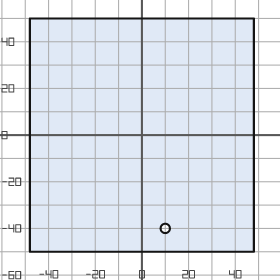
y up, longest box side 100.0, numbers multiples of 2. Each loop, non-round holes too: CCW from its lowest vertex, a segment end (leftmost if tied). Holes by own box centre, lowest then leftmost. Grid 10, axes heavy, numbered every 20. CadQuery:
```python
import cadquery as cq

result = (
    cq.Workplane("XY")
    .moveTo(-48.0, -50.0)
    .lineTo(48.0, -50.0)
    .lineTo(48.0, 50.0)
    .lineTo(-48.0, 50.0)
    .close()
    .moveTo(10.0, -40.0)
    .circle(2.0)
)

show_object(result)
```